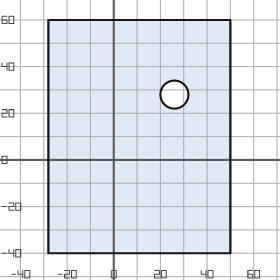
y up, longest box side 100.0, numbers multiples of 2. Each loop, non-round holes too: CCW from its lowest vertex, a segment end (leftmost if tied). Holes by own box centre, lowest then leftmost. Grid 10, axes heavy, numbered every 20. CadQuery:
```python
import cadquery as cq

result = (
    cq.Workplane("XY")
    .moveTo(-28.0, -40.0)
    .lineTo(50.0, -40.0)
    .lineTo(50.0, 60.0)
    .lineTo(-28.0, 60.0)
    .close()
    .moveTo(26.0, 28.0)
    .circle(6.0)
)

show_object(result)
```